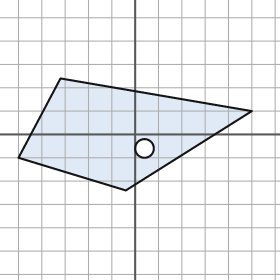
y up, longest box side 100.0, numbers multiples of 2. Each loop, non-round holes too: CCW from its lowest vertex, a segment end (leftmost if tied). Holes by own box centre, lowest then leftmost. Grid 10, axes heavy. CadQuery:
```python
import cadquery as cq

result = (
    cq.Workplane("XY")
    .moveTo(-4.0, -24.0)
    .lineTo(50.0, 10.0)
    .lineTo(-32.0, 24.0)
    .lineTo(-50.0, -10.0)
    .close()
    .moveTo(4.0, -6.0)
    .circle(4.0)
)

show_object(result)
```